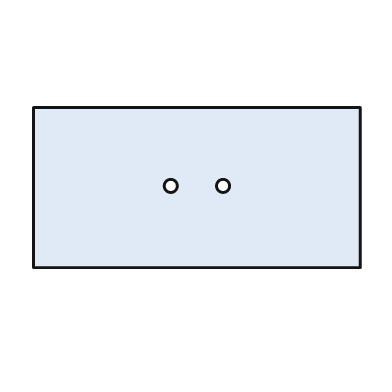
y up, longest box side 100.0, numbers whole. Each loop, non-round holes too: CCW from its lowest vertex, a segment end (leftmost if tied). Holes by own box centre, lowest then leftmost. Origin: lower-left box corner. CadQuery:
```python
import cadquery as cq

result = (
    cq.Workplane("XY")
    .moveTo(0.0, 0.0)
    .lineTo(100.0, 0.0)
    .lineTo(100.0, 49.0)
    .lineTo(0.0, 49.0)
    .close()
    .moveTo(42.0, 25.0)
    .circle(2.0)
    .moveTo(58.0, 25.0)
    .circle(2.0)
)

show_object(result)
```